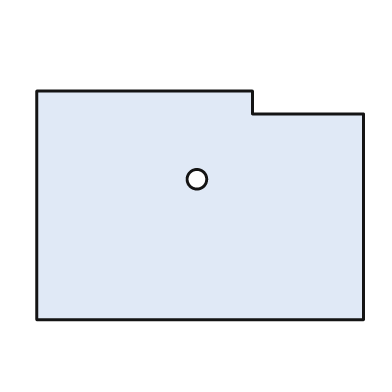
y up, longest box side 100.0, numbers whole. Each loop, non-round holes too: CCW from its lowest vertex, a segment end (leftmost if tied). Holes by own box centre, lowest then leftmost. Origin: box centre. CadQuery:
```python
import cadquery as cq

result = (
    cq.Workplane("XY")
    .moveTo(-50.0, -35.0)
    .lineTo(50.0, -35.0)
    .lineTo(50.0, 28.0)
    .lineTo(16.0, 28.0)
    .lineTo(16.0, 35.0)
    .lineTo(-50.0, 35.0)
    .close()
    .moveTo(-1.0, 8.0)
    .circle(3.0)
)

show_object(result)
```